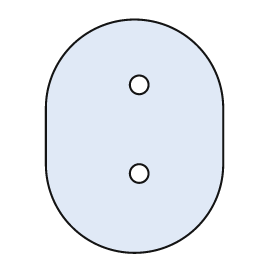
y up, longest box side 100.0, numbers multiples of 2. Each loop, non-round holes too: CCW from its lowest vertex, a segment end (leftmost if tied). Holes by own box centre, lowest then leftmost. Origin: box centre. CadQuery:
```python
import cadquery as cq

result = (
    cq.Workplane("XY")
    .moveTo(-38.0, -12.0)
    .threePointArc((0.0, -50.0), (38.0, -12.0))
    .lineTo(38.0, 12.0)
    .threePointArc((0.0, 50.0), (-38.0, 12.0))
    .close()
    .moveTo(2.0, -16.0)
    .circle(4.0)
    .moveTo(2.0, 22.0)
    .circle(4.0)
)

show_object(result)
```